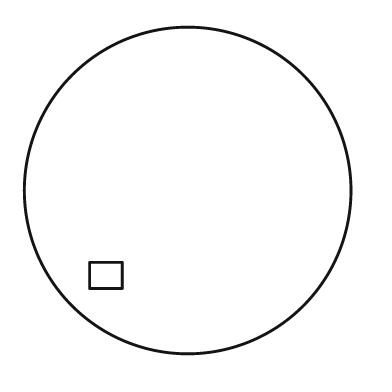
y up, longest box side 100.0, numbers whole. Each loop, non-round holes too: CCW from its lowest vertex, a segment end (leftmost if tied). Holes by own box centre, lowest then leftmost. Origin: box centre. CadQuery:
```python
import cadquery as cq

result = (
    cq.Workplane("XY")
    .moveTo(0.0, 0.0)
    .circle(50.0)
    .moveTo(-30.0, -30.0)
    .lineTo(-20.0, -30.0)
    .lineTo(-20.0, -22.0)
    .lineTo(-30.0, -22.0)
    .close()
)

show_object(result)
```